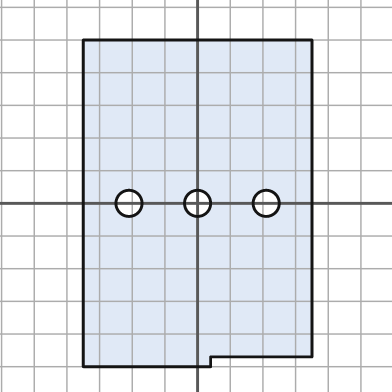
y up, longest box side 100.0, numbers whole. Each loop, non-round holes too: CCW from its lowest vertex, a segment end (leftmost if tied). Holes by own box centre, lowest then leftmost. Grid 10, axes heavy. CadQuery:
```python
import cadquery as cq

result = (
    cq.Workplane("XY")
    .moveTo(-35.0, -50.0)
    .lineTo(4.0, -50.0)
    .lineTo(4.0, -47.0)
    .lineTo(35.0, -47.0)
    .lineTo(35.0, 50.0)
    .lineTo(-35.0, 50.0)
    .close()
    .moveTo(-21.0, 0.0)
    .circle(4.0)
    .moveTo(0.0, 0.0)
    .circle(4.0)
    .moveTo(21.0, 0.0)
    .circle(4.0)
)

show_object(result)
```